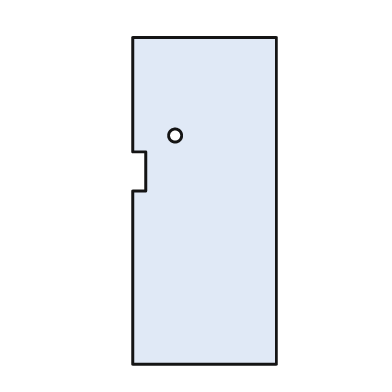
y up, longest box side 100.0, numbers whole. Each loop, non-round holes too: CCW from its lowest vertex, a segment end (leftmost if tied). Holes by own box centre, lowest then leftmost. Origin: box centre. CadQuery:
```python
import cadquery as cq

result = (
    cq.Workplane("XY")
    .moveTo(-22.0, -50.0)
    .lineTo(22.0, -50.0)
    .lineTo(22.0, 50.0)
    .lineTo(-22.0, 50.0)
    .lineTo(-22.0, 15.0)
    .lineTo(-18.0, 15.0)
    .lineTo(-18.0, 3.0)
    .lineTo(-22.0, 3.0)
    .close()
    .moveTo(-9.0, 20.0)
    .circle(2.0)
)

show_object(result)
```